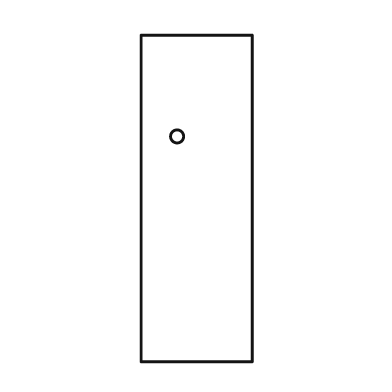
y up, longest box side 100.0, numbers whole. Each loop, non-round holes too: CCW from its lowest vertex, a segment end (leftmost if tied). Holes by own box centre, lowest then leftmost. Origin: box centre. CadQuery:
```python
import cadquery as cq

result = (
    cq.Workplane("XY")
    .moveTo(-17.0, -50.0)
    .lineTo(17.0, -50.0)
    .lineTo(17.0, 50.0)
    .lineTo(-17.0, 50.0)
    .close()
    .moveTo(-6.0, 19.0)
    .circle(2.0)
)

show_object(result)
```